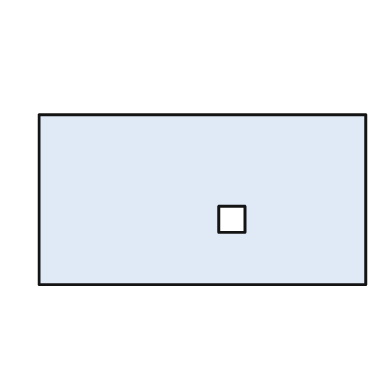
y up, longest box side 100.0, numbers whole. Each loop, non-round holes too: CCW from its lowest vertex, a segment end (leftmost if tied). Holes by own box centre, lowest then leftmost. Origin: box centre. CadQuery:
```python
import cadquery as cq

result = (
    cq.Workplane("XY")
    .moveTo(-50.0, -26.0)
    .lineTo(50.0, -26.0)
    .lineTo(50.0, 26.0)
    .lineTo(-50.0, 26.0)
    .close()
    .moveTo(5.0, -10.0)
    .lineTo(13.0, -10.0)
    .lineTo(13.0, -2.0)
    .lineTo(5.0, -2.0)
    .close()
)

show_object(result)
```